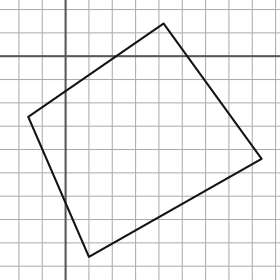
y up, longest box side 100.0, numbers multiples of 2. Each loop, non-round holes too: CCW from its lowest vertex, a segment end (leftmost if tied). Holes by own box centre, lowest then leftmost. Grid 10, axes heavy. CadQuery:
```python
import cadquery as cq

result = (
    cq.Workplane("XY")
    .moveTo(10.0, -86.0)
    .lineTo(84.0, -44.0)
    .lineTo(42.0, 14.0)
    .lineTo(-16.0, -26.0)
    .close()
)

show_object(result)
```